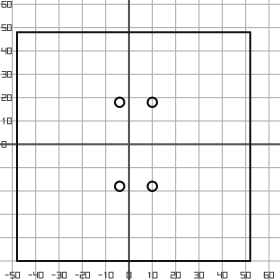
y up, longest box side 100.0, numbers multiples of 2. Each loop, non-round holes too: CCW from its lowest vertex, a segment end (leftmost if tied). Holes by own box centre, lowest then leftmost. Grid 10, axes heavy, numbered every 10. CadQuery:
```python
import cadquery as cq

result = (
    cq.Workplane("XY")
    .moveTo(-48.0, -50.0)
    .lineTo(52.0, -50.0)
    .lineTo(52.0, 48.0)
    .lineTo(-48.0, 48.0)
    .close()
    .moveTo(-4.0, -18.0)
    .circle(2.0)
    .moveTo(10.0, -18.0)
    .circle(2.0)
    .moveTo(-4.0, 18.0)
    .circle(2.0)
    .moveTo(10.0, 18.0)
    .circle(2.0)
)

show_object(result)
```